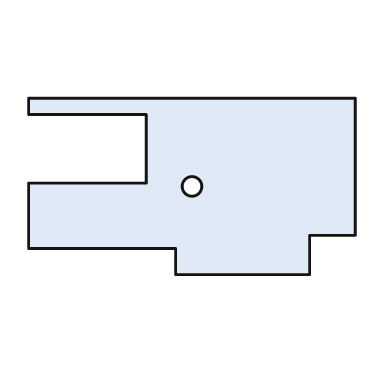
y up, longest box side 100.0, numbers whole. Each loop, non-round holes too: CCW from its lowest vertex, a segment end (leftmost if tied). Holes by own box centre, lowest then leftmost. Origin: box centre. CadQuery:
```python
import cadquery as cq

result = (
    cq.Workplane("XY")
    .moveTo(-5.0, -27.0)
    .lineTo(36.0, -27.0)
    .lineTo(36.0, -15.0)
    .lineTo(50.0, -15.0)
    .lineTo(50.0, 27.0)
    .lineTo(-50.0, 27.0)
    .lineTo(-50.0, 22.0)
    .lineTo(-14.0, 22.0)
    .lineTo(-14.0, 1.0)
    .lineTo(-50.0, 1.0)
    .lineTo(-50.0, -19.0)
    .lineTo(-5.0, -19.0)
    .close()
    .moveTo(0.0, 0.0)
    .circle(3.0)
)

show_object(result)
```